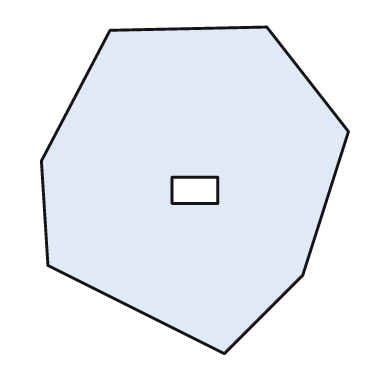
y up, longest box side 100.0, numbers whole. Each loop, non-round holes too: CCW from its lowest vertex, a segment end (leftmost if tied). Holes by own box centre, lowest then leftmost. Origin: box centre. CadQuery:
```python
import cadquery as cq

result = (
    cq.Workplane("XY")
    .moveTo(9.0, -50.0)
    .lineTo(33.0, -26.0)
    .lineTo(47.0, 18.0)
    .lineTo(22.0, 50.0)
    .lineTo(-26.0, 49.0)
    .lineTo(-47.0, 9.0)
    .lineTo(-45.0, -23.0)
    .close()
    .moveTo(-7.0, -4.0)
    .lineTo(7.0, -4.0)
    .lineTo(7.0, 4.0)
    .lineTo(-7.0, 4.0)
    .close()
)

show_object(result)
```